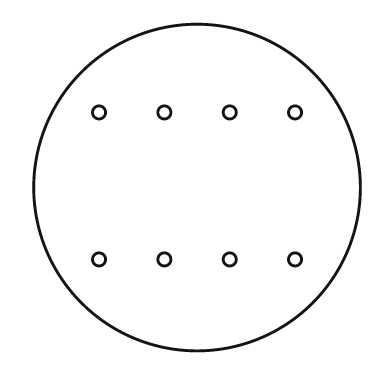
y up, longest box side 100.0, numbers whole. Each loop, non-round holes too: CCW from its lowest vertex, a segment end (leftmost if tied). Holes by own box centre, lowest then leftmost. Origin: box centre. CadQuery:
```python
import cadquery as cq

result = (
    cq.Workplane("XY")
    .moveTo(0.0, 0.0)
    .circle(50.0)
    .moveTo(-30.0, -22.0)
    .circle(2.0)
    .moveTo(-10.0, -22.0)
    .circle(2.0)
    .moveTo(10.0, -22.0)
    .circle(2.0)
    .moveTo(30.0, -22.0)
    .circle(2.0)
    .moveTo(-30.0, 23.0)
    .circle(2.0)
    .moveTo(-10.0, 23.0)
    .circle(2.0)
    .moveTo(10.0, 23.0)
    .circle(2.0)
    .moveTo(30.0, 23.0)
    .circle(2.0)
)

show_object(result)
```